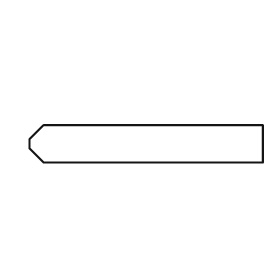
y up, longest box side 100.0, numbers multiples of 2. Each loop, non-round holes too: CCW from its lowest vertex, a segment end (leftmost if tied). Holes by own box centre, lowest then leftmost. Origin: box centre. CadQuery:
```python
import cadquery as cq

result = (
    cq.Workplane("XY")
    .moveTo(-44.0, -8.0)
    .lineTo(50.0, -8.0)
    .lineTo(50.0, 8.0)
    .lineTo(-44.0, 8.0)
    .lineTo(-50.0, 2.0)
    .lineTo(-50.0, -2.0)
    .close()
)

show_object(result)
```